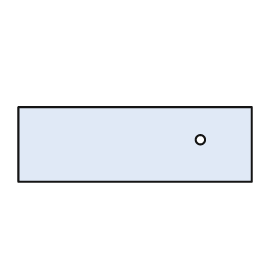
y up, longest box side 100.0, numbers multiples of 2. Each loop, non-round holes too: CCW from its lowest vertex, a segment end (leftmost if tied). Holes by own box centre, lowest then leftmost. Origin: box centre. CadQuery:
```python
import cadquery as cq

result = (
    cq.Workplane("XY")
    .moveTo(-50.0, -16.0)
    .lineTo(50.0, -16.0)
    .lineTo(50.0, 16.0)
    .lineTo(-50.0, 16.0)
    .close()
    .moveTo(28.0, 2.0)
    .circle(2.0)
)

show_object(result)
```